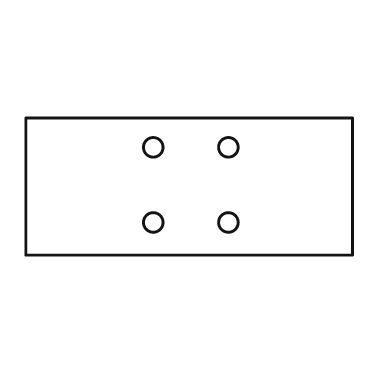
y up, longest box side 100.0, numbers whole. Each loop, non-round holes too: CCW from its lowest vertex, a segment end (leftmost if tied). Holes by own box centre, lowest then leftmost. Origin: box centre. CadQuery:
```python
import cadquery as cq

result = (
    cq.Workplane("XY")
    .moveTo(-50.0, -21.0)
    .lineTo(50.0, -21.0)
    .lineTo(50.0, 21.0)
    .lineTo(-50.0, 21.0)
    .close()
    .moveTo(-11.0, -11.0)
    .circle(3.0)
    .moveTo(12.0, -11.0)
    .circle(3.0)
    .moveTo(-11.0, 12.0)
    .circle(3.0)
    .moveTo(12.0, 12.0)
    .circle(3.0)
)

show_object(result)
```